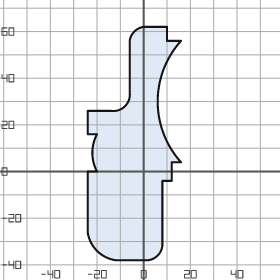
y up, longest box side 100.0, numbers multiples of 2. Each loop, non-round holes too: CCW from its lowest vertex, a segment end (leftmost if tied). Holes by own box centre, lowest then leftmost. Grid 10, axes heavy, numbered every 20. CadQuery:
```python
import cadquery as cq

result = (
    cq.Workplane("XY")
    .moveTo(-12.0, -38.0)
    .lineTo(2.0, -38.0)
    .threePointArc((6.0, -36.0), (8.0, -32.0))
    .lineTo(8.0, -4.0)
    .lineTo(12.0, -4.0)
    .lineTo(12.0, 4.0)
    .lineTo(16.0, 4.0)
    .threePointArc((6.0, 30.0), (16.0, 56.0))
    .lineTo(10.0, 56.0)
    .lineTo(10.0, 62.0)
    .lineTo(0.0, 62.0)
    .threePointArc((-4.0, 60.0), (-6.0, 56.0))
    .lineTo(-6.0, 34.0)
    .threePointArc((-8.0, 28.0), (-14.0, 26.0))
    .lineTo(-24.0, 26.0)
    .lineTo(-24.0, 16.0)
    .lineTo(-20.0, 16.0)
    .threePointArc((-22.0, 8.0), (-20.0, 0.0))
    .lineTo(-24.0, 0.0)
    .lineTo(-24.0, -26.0)
    .threePointArc((-20.0, -34.0), (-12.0, -38.0))
    .close()
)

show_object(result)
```